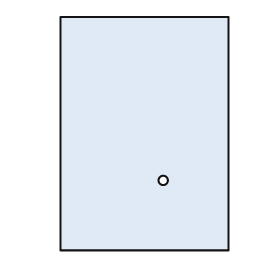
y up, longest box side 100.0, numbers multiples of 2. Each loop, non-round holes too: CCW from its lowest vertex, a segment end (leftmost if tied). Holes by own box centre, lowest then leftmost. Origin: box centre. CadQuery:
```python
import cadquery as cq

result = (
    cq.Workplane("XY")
    .moveTo(-36.0, -50.0)
    .lineTo(36.0, -50.0)
    .lineTo(36.0, 50.0)
    .lineTo(-36.0, 50.0)
    .close()
    .moveTo(8.0, -20.0)
    .circle(2.0)
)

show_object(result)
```